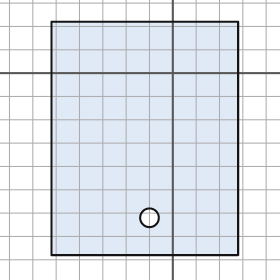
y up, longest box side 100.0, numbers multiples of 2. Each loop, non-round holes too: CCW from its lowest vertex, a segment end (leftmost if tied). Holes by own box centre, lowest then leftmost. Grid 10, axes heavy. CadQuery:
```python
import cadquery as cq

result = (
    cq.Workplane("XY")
    .moveTo(-52.0, -78.0)
    .lineTo(28.0, -78.0)
    .lineTo(28.0, 22.0)
    .lineTo(-52.0, 22.0)
    .close()
    .moveTo(-10.0, -62.0)
    .circle(4.0)
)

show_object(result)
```